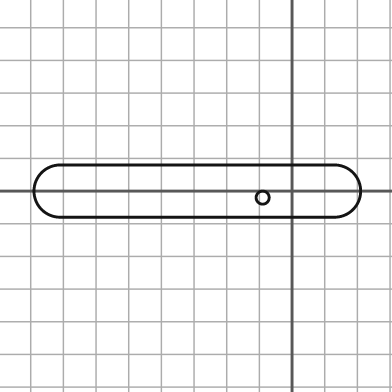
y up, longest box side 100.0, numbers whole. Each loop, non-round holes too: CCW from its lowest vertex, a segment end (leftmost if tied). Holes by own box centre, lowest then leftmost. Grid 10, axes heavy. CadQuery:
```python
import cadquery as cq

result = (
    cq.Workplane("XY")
    .moveTo(-71.0, -8.0)
    .lineTo(13.0, -8.0)
    .threePointArc((21.0, 0.0), (13.0, 8.0))
    .lineTo(-71.0, 8.0)
    .threePointArc((-79.0, 0.0), (-71.0, -8.0))
    .close()
    .moveTo(-9.0, -2.0)
    .circle(2.0)
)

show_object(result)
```